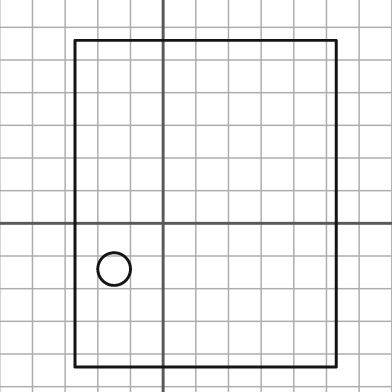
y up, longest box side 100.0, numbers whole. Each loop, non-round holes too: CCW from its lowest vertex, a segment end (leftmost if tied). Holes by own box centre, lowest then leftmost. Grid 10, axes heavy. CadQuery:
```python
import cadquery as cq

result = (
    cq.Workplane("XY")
    .moveTo(-27.0, -44.0)
    .lineTo(53.0, -44.0)
    .lineTo(53.0, 56.0)
    .lineTo(-27.0, 56.0)
    .close()
    .moveTo(-15.0, -14.0)
    .circle(5.0)
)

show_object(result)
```